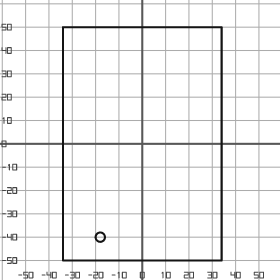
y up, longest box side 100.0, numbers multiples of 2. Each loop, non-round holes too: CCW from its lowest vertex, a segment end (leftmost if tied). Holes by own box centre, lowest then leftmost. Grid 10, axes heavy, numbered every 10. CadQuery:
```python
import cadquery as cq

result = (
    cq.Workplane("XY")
    .moveTo(-34.0, -50.0)
    .lineTo(34.0, -50.0)
    .lineTo(34.0, 50.0)
    .lineTo(-34.0, 50.0)
    .close()
    .moveTo(-18.0, -40.0)
    .circle(2.0)
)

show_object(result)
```